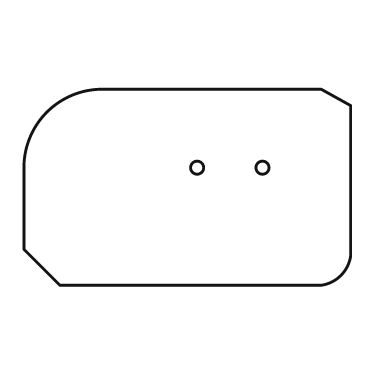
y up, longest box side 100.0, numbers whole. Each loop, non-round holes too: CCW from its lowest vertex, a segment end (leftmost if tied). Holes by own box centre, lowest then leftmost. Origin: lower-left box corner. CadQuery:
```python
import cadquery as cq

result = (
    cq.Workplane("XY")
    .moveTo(11.0, 0.0)
    .lineTo(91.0, 0.0)
    .threePointArc((97.0, 3.0), (100.0, 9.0))
    .lineTo(100.0, 55.0)
    .lineTo(91.0, 60.0)
    .lineTo(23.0, 60.0)
    .threePointArc((7.0, 53.0), (0.0, 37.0))
    .lineTo(0.0, 11.0)
    .close()
    .moveTo(53.0, 36.0)
    .circle(2.0)
    .moveTo(73.0, 36.0)
    .circle(2.0)
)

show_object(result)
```